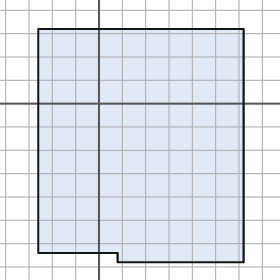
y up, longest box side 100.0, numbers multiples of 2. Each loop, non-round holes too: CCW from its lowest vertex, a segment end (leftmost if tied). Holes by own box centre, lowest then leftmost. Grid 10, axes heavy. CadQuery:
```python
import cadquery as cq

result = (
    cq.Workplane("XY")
    .moveTo(8.0, -68.0)
    .lineTo(62.0, -68.0)
    .lineTo(62.0, 32.0)
    .lineTo(-26.0, 32.0)
    .lineTo(-26.0, -64.0)
    .lineTo(8.0, -64.0)
    .close()
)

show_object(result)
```